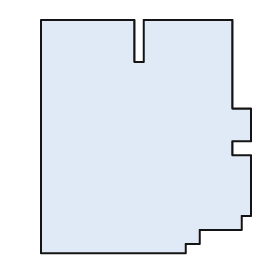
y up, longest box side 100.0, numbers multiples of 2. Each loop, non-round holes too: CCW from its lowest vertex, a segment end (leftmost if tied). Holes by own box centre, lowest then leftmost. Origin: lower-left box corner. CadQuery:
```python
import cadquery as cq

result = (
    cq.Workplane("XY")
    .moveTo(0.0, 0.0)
    .lineTo(62.0, 0.0)
    .lineTo(62.0, 4.0)
    .lineTo(68.0, 4.0)
    .lineTo(68.0, 10.0)
    .lineTo(86.0, 10.0)
    .lineTo(86.0, 16.0)
    .lineTo(90.0, 16.0)
    .lineTo(90.0, 42.0)
    .lineTo(82.0, 42.0)
    .lineTo(82.0, 48.0)
    .lineTo(90.0, 48.0)
    .lineTo(90.0, 62.0)
    .lineTo(82.0, 62.0)
    .lineTo(82.0, 100.0)
    .lineTo(44.0, 100.0)
    .lineTo(44.0, 82.0)
    .lineTo(40.0, 82.0)
    .lineTo(40.0, 100.0)
    .lineTo(0.0, 100.0)
    .close()
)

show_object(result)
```